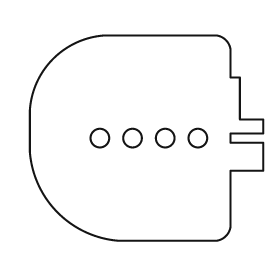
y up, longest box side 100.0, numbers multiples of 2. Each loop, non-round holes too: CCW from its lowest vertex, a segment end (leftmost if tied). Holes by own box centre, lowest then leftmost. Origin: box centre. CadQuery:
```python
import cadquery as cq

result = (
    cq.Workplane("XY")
    .moveTo(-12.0, -44.0)
    .lineTo(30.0, -44.0)
    .threePointArc((34.0, -42.0), (36.0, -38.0))
    .lineTo(36.0, -14.0)
    .lineTo(50.0, -14.0)
    .lineTo(50.0, -2.0)
    .lineTo(36.0, -2.0)
    .lineTo(36.0, 2.0)
    .lineTo(50.0, 2.0)
    .lineTo(50.0, 8.0)
    .lineTo(40.0, 8.0)
    .lineTo(40.0, 26.0)
    .lineTo(36.0, 26.0)
    .lineTo(36.0, 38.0)
    .threePointArc((34.0, 42.0), (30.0, 44.0))
    .lineTo(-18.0, 44.0)
    .threePointArc((-40.0, 34.0), (-50.0, 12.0))
    .lineTo(-50.0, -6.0)
    .threePointArc((-38.0, -32.0), (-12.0, -44.0))
    .close()
    .moveTo(-20.0, 0.0)
    .circle(4.0)
    .moveTo(-6.0, 0.0)
    .circle(4.0)
    .moveTo(8.0, 0.0)
    .circle(4.0)
    .moveTo(22.0, 0.0)
    .circle(4.0)
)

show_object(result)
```